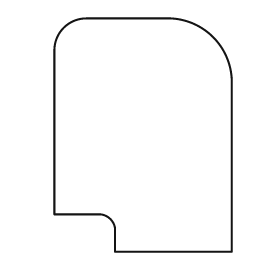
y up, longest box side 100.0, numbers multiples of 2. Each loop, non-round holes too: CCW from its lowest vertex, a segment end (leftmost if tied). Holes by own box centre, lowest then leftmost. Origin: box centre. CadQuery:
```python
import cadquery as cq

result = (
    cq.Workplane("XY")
    .moveTo(-12.0, -50.0)
    .lineTo(38.0, -50.0)
    .lineTo(38.0, 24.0)
    .threePointArc((30.0, 42.0), (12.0, 50.0))
    .lineTo(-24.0, 50.0)
    .threePointArc((-34.0, 46.0), (-38.0, 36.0))
    .lineTo(-38.0, -34.0)
    .lineTo(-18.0, -34.0)
    .threePointArc((-14.0, -36.0), (-12.0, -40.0))
    .close()
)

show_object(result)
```